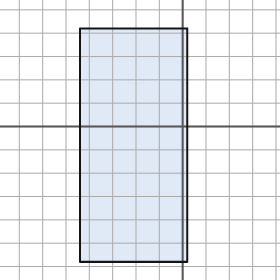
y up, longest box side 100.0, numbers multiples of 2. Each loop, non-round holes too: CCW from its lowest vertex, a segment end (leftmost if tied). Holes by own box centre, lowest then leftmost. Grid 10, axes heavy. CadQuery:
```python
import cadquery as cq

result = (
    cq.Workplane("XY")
    .moveTo(-44.0, -58.0)
    .lineTo(2.0, -58.0)
    .lineTo(2.0, 42.0)
    .lineTo(-44.0, 42.0)
    .close()
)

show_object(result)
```